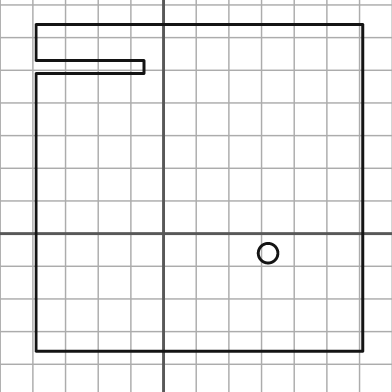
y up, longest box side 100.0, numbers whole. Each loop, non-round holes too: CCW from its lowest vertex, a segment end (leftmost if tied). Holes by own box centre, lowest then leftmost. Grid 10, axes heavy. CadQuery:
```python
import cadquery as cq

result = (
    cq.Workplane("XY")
    .moveTo(-39.0, -36.0)
    .lineTo(61.0, -36.0)
    .lineTo(61.0, 64.0)
    .lineTo(-39.0, 64.0)
    .lineTo(-39.0, 53.0)
    .lineTo(-6.0, 53.0)
    .lineTo(-6.0, 49.0)
    .lineTo(-39.0, 49.0)
    .close()
    .moveTo(32.0, -6.0)
    .circle(3.0)
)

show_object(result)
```